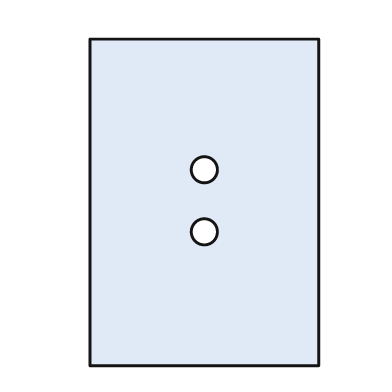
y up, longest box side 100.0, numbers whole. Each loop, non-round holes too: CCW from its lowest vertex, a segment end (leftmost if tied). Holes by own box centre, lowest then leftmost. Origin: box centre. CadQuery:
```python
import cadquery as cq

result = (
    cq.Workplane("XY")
    .moveTo(-35.0, -50.0)
    .lineTo(35.0, -50.0)
    .lineTo(35.0, 50.0)
    .lineTo(-35.0, 50.0)
    .close()
    .moveTo(0.0, -9.0)
    .circle(4.0)
    .moveTo(0.0, 10.0)
    .circle(4.0)
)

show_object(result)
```